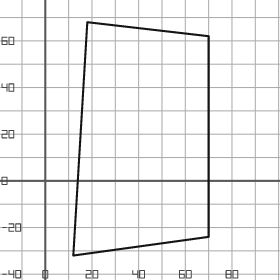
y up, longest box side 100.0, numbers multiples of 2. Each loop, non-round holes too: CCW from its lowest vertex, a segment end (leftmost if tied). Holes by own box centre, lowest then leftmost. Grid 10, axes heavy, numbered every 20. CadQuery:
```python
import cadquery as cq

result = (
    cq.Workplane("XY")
    .moveTo(12.0, -32.0)
    .lineTo(70.0, -24.0)
    .lineTo(70.0, 62.0)
    .lineTo(18.0, 68.0)
    .close()
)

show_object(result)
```